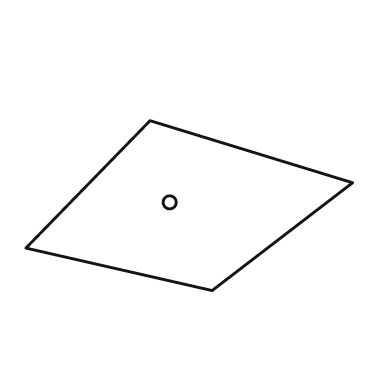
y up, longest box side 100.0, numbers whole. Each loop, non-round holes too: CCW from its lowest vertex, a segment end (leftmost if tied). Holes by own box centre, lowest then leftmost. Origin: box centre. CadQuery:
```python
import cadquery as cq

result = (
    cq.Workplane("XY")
    .moveTo(7.0, -26.0)
    .lineTo(50.0, 7.0)
    .lineTo(-12.0, 26.0)
    .lineTo(-50.0, -13.0)
    .close()
    .moveTo(-6.0, 1.0)
    .circle(2.0)
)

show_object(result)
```